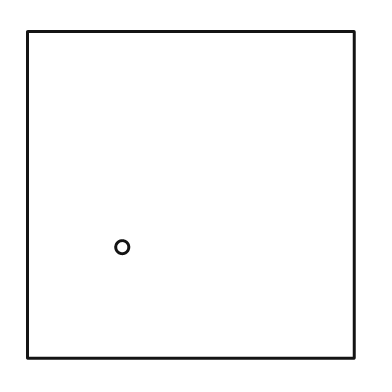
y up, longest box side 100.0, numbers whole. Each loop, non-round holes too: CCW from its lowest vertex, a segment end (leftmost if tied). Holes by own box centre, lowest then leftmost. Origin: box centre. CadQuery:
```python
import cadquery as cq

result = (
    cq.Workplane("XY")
    .moveTo(-50.0, -50.0)
    .lineTo(50.0, -50.0)
    .lineTo(50.0, 50.0)
    .lineTo(-50.0, 50.0)
    .close()
    .moveTo(-21.0, -16.0)
    .circle(2.0)
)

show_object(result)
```